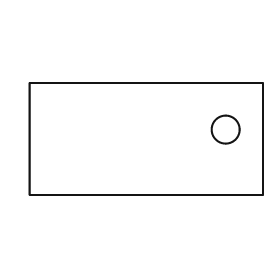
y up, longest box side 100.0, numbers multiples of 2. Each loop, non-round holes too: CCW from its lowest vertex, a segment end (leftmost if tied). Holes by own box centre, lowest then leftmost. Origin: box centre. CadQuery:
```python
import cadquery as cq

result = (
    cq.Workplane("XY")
    .moveTo(-50.0, -24.0)
    .lineTo(50.0, -24.0)
    .lineTo(50.0, 24.0)
    .lineTo(-50.0, 24.0)
    .close()
    .moveTo(34.0, 4.0)
    .circle(6.0)
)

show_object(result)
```